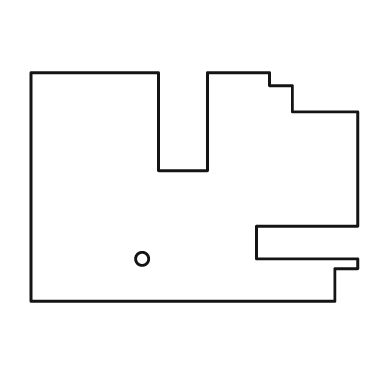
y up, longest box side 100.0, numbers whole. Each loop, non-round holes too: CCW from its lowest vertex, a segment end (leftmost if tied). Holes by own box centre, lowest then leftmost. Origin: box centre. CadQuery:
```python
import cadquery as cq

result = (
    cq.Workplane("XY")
    .moveTo(-50.0, -35.0)
    .lineTo(43.0, -35.0)
    .lineTo(43.0, -25.0)
    .lineTo(50.0, -25.0)
    .lineTo(50.0, -22.0)
    .lineTo(19.0, -22.0)
    .lineTo(19.0, -12.0)
    .lineTo(50.0, -12.0)
    .lineTo(50.0, 23.0)
    .lineTo(30.0, 23.0)
    .lineTo(30.0, 31.0)
    .lineTo(23.0, 31.0)
    .lineTo(23.0, 35.0)
    .lineTo(4.0, 35.0)
    .lineTo(4.0, 5.0)
    .lineTo(-11.0, 5.0)
    .lineTo(-11.0, 35.0)
    .lineTo(-50.0, 35.0)
    .close()
    .moveTo(-16.0, -22.0)
    .circle(2.0)
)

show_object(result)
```